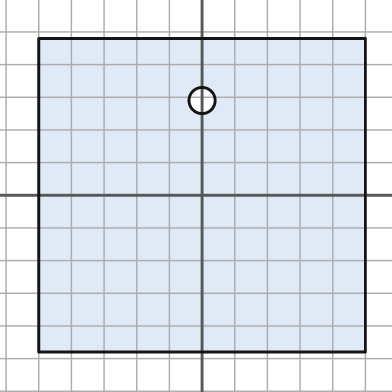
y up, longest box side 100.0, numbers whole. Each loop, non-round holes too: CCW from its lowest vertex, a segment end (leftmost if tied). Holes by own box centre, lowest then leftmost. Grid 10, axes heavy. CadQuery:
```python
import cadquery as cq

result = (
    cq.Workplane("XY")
    .moveTo(-50.0, -48.0)
    .lineTo(50.0, -48.0)
    .lineTo(50.0, 48.0)
    .lineTo(-50.0, 48.0)
    .close()
    .moveTo(0.0, 29.0)
    .circle(4.0)
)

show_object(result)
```